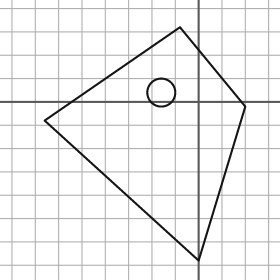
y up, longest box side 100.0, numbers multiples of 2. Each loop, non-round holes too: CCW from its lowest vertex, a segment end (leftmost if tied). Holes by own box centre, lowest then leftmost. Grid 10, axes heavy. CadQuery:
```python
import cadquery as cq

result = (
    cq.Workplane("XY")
    .moveTo(0.0, -68.0)
    .lineTo(20.0, -2.0)
    .lineTo(-8.0, 32.0)
    .lineTo(-66.0, -8.0)
    .close()
    .moveTo(-16.0, 4.0)
    .circle(6.0)
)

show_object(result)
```